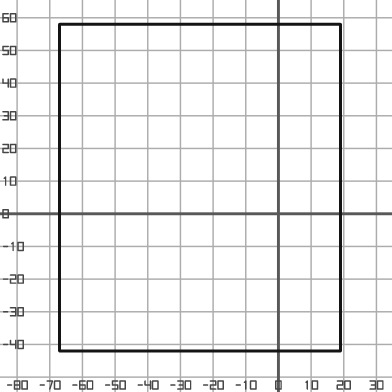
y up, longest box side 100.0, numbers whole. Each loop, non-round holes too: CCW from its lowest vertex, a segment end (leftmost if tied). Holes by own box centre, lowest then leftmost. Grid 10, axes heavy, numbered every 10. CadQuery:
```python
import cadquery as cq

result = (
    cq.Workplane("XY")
    .moveTo(-67.0, -42.0)
    .lineTo(19.0, -42.0)
    .lineTo(19.0, 58.0)
    .lineTo(-67.0, 58.0)
    .close()
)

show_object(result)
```